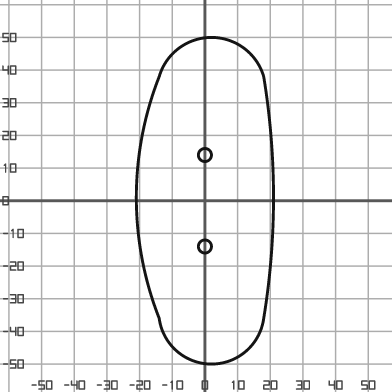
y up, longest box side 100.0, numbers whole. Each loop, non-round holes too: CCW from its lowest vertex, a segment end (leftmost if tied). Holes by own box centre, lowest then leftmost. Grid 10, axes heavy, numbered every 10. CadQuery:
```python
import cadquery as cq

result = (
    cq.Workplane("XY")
    .moveTo(-14.0, -36.0)
    .threePointArc((2.0, -50.0), (18.0, -36.0))
    .threePointArc((21.0, 1.0), (18.0, 38.0))
    .threePointArc((2.0, 50.0), (-14.0, 38.0))
    .threePointArc((-21.0, 1.0), (-14.0, -36.0))
    .close()
    .moveTo(0.0, -14.0)
    .circle(2.0)
    .moveTo(0.0, 14.0)
    .circle(2.0)
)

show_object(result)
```